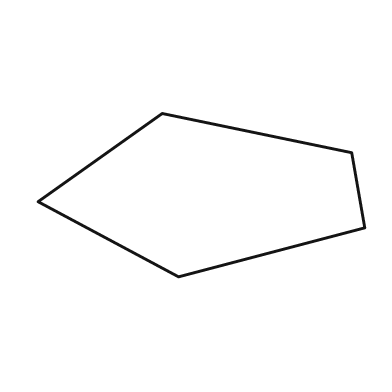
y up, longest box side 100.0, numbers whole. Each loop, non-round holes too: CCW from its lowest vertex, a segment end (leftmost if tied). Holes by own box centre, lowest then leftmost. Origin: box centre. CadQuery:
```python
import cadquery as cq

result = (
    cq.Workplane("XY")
    .moveTo(-7.0, -25.0)
    .lineTo(50.0, -10.0)
    .lineTo(46.0, 13.0)
    .lineTo(-12.0, 25.0)
    .lineTo(-50.0, -2.0)
    .close()
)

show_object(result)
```